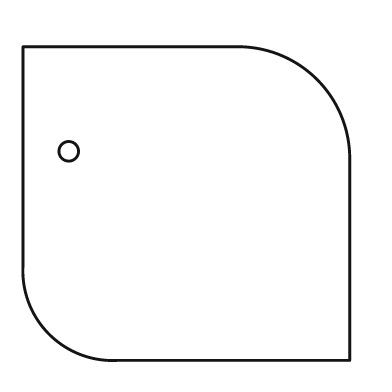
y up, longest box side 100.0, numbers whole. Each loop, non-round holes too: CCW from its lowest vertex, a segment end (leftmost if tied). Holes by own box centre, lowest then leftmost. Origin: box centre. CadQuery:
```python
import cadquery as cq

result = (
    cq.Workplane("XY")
    .moveTo(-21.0, -48.0)
    .lineTo(50.0, -48.0)
    .lineTo(50.0, 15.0)
    .threePointArc((40.0, 38.0), (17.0, 48.0))
    .lineTo(-50.0, 48.0)
    .lineTo(-50.0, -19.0)
    .threePointArc((-42.0, -40.0), (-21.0, -48.0))
    .close()
    .moveTo(-36.0, 16.0)
    .circle(3.0)
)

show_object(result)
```